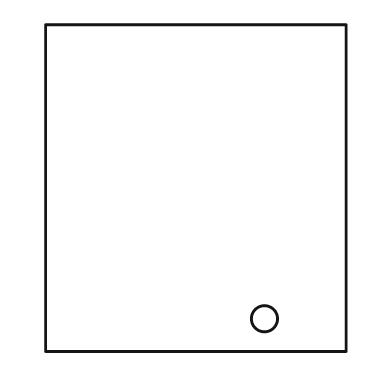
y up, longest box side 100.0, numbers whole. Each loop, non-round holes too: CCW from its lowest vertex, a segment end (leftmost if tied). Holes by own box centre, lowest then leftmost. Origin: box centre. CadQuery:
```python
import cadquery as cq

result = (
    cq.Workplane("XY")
    .moveTo(-46.0, -50.0)
    .lineTo(46.0, -50.0)
    .lineTo(46.0, 50.0)
    .lineTo(-46.0, 50.0)
    .close()
    .moveTo(21.0, -40.0)
    .circle(4.0)
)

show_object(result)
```